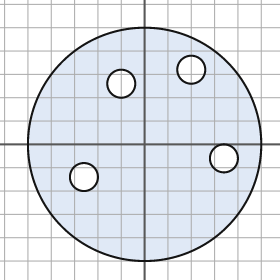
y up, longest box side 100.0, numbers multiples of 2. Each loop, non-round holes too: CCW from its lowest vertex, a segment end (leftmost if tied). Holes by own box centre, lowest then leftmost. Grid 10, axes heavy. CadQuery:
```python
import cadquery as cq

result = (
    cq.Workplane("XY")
    .moveTo(0.0, 0.0)
    .circle(50.0)
    .moveTo(-26.0, -14.0)
    .circle(6.0)
    .moveTo(34.0, -6.0)
    .circle(6.0)
    .moveTo(-10.0, 26.0)
    .circle(6.0)
    .moveTo(20.0, 32.0)
    .circle(6.0)
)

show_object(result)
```